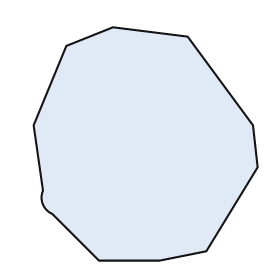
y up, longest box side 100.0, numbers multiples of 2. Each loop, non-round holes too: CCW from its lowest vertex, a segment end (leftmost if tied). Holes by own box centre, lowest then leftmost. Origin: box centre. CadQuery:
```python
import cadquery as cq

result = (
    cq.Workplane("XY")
    .moveTo(-20.0, -50.0)
    .lineTo(6.0, -50.0)
    .lineTo(26.0, -46.0)
    .lineTo(48.0, -10.0)
    .lineTo(46.0, 8.0)
    .lineTo(18.0, 46.0)
    .lineTo(-14.0, 50.0)
    .lineTo(-34.0, 42.0)
    .lineTo(-48.0, 8.0)
    .lineTo(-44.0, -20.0)
    .threePointArc((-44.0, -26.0), (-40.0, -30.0))
    .close()
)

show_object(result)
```